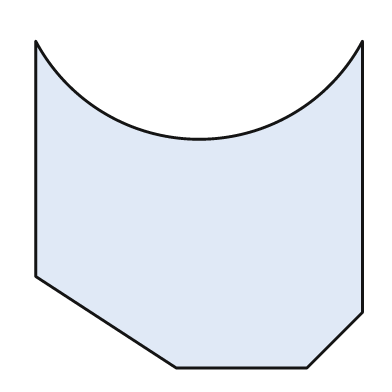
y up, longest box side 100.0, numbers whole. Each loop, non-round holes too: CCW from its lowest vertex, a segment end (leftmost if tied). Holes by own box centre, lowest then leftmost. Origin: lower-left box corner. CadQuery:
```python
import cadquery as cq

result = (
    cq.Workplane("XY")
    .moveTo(43.0, 0.0)
    .lineTo(83.0, 0.0)
    .lineTo(100.0, 17.0)
    .lineTo(100.0, 100.0)
    .threePointArc((50.0, 70.0), (0.0, 100.0))
    .lineTo(0.0, 28.0)
    .close()
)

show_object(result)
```